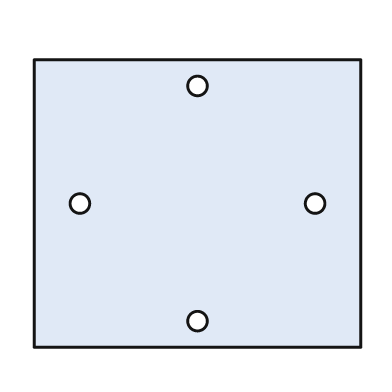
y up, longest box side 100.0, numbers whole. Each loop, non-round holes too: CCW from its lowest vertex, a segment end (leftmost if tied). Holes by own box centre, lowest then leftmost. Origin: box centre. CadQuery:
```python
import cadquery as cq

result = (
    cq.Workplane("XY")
    .moveTo(-50.0, -44.0)
    .lineTo(50.0, -44.0)
    .lineTo(50.0, 44.0)
    .lineTo(-50.0, 44.0)
    .close()
    .moveTo(0.0, -36.0)
    .circle(3.0)
    .moveTo(-36.0, 0.0)
    .circle(3.0)
    .moveTo(36.0, 0.0)
    .circle(3.0)
    .moveTo(0.0, 36.0)
    .circle(3.0)
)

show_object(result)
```